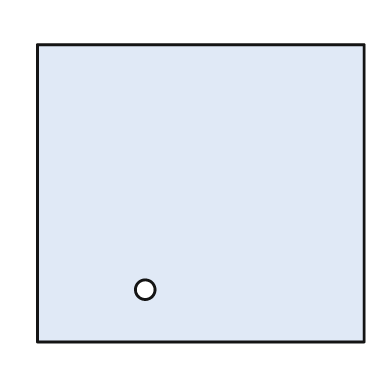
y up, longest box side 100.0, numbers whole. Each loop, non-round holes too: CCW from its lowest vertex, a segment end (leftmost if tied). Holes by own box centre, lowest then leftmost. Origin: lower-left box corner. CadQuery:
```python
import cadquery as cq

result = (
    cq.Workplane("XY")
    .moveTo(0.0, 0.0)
    .lineTo(100.0, 0.0)
    .lineTo(100.0, 91.0)
    .lineTo(0.0, 91.0)
    .close()
    .moveTo(33.0, 16.0)
    .circle(3.0)
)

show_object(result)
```